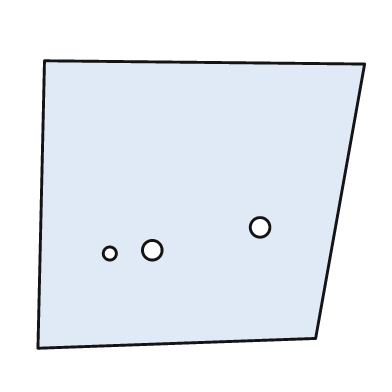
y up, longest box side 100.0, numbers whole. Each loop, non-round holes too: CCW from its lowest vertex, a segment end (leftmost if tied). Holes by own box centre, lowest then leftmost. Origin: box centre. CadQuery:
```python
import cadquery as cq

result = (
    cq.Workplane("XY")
    .moveTo(-50.0, -44.0)
    .lineTo(35.0, -41.0)
    .lineTo(50.0, 43.0)
    .lineTo(-48.0, 44.0)
    .close()
    .moveTo(-28.0, -15.0)
    .circle(2.0)
    .moveTo(-15.0, -14.0)
    .circle(3.0)
    .moveTo(18.0, -7.0)
    .circle(3.0)
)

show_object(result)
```